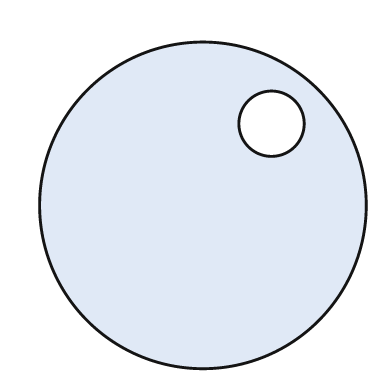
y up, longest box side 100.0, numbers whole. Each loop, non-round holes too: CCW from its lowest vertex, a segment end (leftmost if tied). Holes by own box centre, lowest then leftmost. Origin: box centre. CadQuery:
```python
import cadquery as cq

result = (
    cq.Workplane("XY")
    .moveTo(0.0, 0.0)
    .circle(50.0)
    .moveTo(21.0, 25.0)
    .circle(10.0)
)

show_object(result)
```